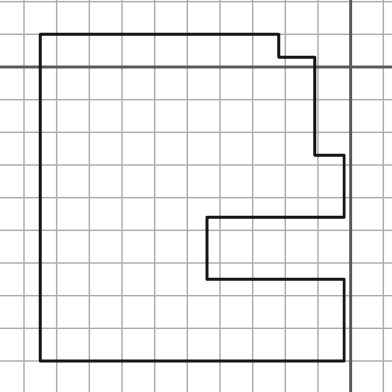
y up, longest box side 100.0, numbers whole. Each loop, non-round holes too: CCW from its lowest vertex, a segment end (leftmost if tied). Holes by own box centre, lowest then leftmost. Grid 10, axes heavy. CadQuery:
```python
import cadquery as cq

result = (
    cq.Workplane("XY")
    .moveTo(-95.0, -90.0)
    .lineTo(-2.0, -90.0)
    .lineTo(-2.0, -65.0)
    .lineTo(-44.0, -65.0)
    .lineTo(-44.0, -46.0)
    .lineTo(-2.0, -46.0)
    .lineTo(-2.0, -27.0)
    .lineTo(-11.0, -27.0)
    .lineTo(-11.0, 3.0)
    .lineTo(-22.0, 3.0)
    .lineTo(-22.0, 10.0)
    .lineTo(-95.0, 10.0)
    .close()
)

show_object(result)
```